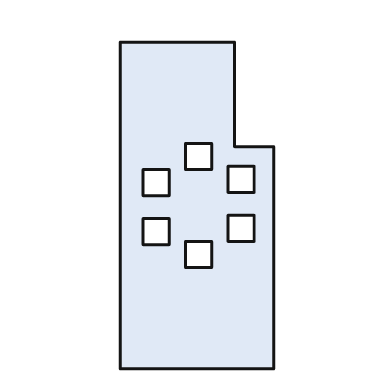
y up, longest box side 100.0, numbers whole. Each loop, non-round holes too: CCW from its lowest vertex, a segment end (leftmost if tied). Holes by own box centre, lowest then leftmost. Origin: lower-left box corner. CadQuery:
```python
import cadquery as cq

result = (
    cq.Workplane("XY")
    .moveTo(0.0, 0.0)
    .lineTo(47.0, 0.0)
    .lineTo(47.0, 68.0)
    .lineTo(35.0, 68.0)
    .lineTo(35.0, 100.0)
    .lineTo(0.0, 100.0)
    .close()
    .moveTo(20.0, 31.0)
    .lineTo(28.0, 31.0)
    .lineTo(28.0, 39.0)
    .lineTo(20.0, 39.0)
    .close()
    .moveTo(7.0, 38.0)
    .lineTo(15.0, 38.0)
    .lineTo(15.0, 46.0)
    .lineTo(7.0, 46.0)
    .close()
    .moveTo(33.0, 39.0)
    .lineTo(41.0, 39.0)
    .lineTo(41.0, 47.0)
    .lineTo(33.0, 47.0)
    .close()
    .moveTo(7.0, 53.0)
    .lineTo(15.0, 53.0)
    .lineTo(15.0, 61.0)
    .lineTo(7.0, 61.0)
    .close()
    .moveTo(33.0, 54.0)
    .lineTo(41.0, 54.0)
    .lineTo(41.0, 62.0)
    .lineTo(33.0, 62.0)
    .close()
    .moveTo(20.0, 61.0)
    .lineTo(28.0, 61.0)
    .lineTo(28.0, 69.0)
    .lineTo(20.0, 69.0)
    .close()
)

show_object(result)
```